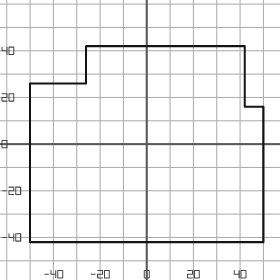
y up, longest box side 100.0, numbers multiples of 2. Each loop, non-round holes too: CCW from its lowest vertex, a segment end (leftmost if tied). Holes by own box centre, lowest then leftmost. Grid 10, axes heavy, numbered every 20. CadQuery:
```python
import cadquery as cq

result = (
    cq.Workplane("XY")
    .moveTo(-50.0, -42.0)
    .lineTo(50.0, -42.0)
    .lineTo(50.0, 16.0)
    .lineTo(42.0, 16.0)
    .lineTo(42.0, 42.0)
    .lineTo(-26.0, 42.0)
    .lineTo(-26.0, 26.0)
    .lineTo(-50.0, 26.0)
    .close()
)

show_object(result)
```